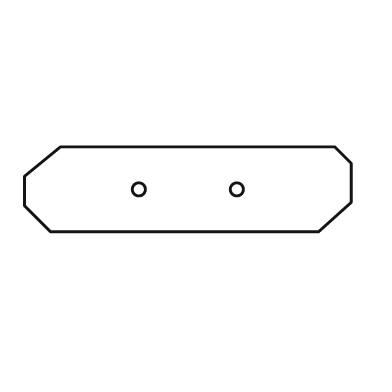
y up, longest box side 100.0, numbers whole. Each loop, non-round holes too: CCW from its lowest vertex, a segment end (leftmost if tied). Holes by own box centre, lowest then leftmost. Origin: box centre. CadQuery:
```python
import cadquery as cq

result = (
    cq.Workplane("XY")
    .moveTo(-42.0, -13.0)
    .lineTo(40.0, -13.0)
    .lineTo(50.0, -4.0)
    .lineTo(50.0, 8.0)
    .lineTo(45.0, 13.0)
    .lineTo(-39.0, 13.0)
    .lineTo(-50.0, 4.0)
    .lineTo(-50.0, -5.0)
    .close()
    .moveTo(-15.0, 0.0)
    .circle(2.0)
    .moveTo(15.0, 0.0)
    .circle(2.0)
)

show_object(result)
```